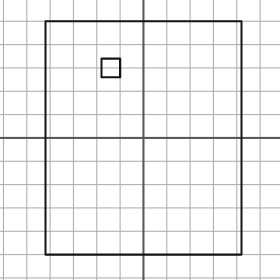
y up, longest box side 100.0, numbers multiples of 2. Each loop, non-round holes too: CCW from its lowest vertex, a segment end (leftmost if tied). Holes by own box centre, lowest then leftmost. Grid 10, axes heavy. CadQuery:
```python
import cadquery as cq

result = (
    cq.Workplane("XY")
    .moveTo(-42.0, -50.0)
    .lineTo(42.0, -50.0)
    .lineTo(42.0, 50.0)
    .lineTo(-42.0, 50.0)
    .close()
    .moveTo(-18.0, 26.0)
    .lineTo(-10.0, 26.0)
    .lineTo(-10.0, 34.0)
    .lineTo(-18.0, 34.0)
    .close()
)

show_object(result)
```